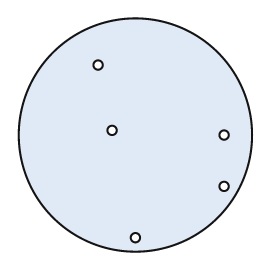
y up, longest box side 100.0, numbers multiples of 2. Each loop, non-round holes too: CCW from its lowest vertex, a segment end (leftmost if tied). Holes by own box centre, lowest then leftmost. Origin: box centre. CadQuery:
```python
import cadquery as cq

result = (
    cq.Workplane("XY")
    .moveTo(0.0, 0.0)
    .circle(50.0)
    .moveTo(0.0, -44.0)
    .circle(2.0)
    .moveTo(38.0, -22.0)
    .circle(2.0)
    .moveTo(38.0, 0.0)
    .circle(2.0)
    .moveTo(-10.0, 2.0)
    .circle(2.0)
    .moveTo(-16.0, 30.0)
    .circle(2.0)
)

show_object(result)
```